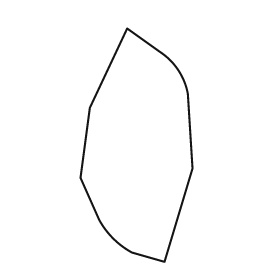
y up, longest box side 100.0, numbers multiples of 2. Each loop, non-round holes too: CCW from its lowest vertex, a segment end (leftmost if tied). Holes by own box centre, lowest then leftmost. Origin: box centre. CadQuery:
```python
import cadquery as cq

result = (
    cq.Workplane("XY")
    .moveTo(12.0, -50.0)
    .lineTo(24.0, -10.0)
    .lineTo(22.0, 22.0)
    .threePointArc((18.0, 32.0), (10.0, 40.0))
    .lineTo(-4.0, 50.0)
    .lineTo(-20.0, 16.0)
    .lineTo(-24.0, -14.0)
    .lineTo(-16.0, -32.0)
    .threePointArc((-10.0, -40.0), (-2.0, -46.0))
    .close()
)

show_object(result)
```